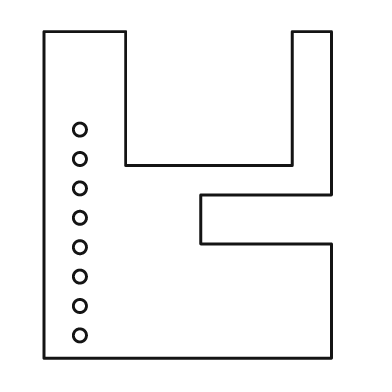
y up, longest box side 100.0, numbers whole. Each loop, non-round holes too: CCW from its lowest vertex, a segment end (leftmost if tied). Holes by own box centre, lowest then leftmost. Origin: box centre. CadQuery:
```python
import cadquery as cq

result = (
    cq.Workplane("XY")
    .moveTo(-44.0, -50.0)
    .lineTo(44.0, -50.0)
    .lineTo(44.0, -15.0)
    .lineTo(4.0, -15.0)
    .lineTo(4.0, 0.0)
    .lineTo(44.0, 0.0)
    .lineTo(44.0, 50.0)
    .lineTo(32.0, 50.0)
    .lineTo(32.0, 9.0)
    .lineTo(-19.0, 9.0)
    .lineTo(-19.0, 50.0)
    .lineTo(-44.0, 50.0)
    .close()
    .moveTo(-33.0, -43.0)
    .circle(2.0)
    .moveTo(-33.0, -34.0)
    .circle(2.0)
    .moveTo(-33.0, -25.0)
    .circle(2.0)
    .moveTo(-33.0, -16.0)
    .circle(2.0)
    .moveTo(-33.0, -7.0)
    .circle(2.0)
    .moveTo(-33.0, 2.0)
    .circle(2.0)
    .moveTo(-33.0, 11.0)
    .circle(2.0)
    .moveTo(-33.0, 20.0)
    .circle(2.0)
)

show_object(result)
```